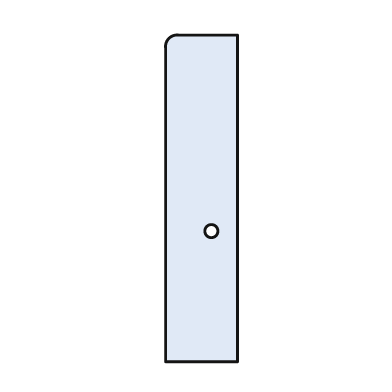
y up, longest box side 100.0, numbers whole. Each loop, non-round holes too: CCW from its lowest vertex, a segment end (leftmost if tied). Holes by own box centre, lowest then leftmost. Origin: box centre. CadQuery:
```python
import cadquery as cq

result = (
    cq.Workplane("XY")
    .moveTo(-11.0, -50.0)
    .lineTo(11.0, -50.0)
    .lineTo(11.0, 50.0)
    .lineTo(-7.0, 50.0)
    .threePointArc((-10.0, 49.0), (-11.0, 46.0))
    .close()
    .moveTo(3.0, -10.0)
    .circle(2.0)
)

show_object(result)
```